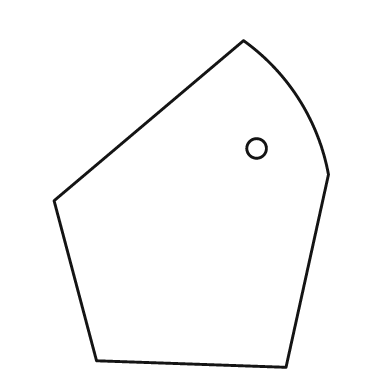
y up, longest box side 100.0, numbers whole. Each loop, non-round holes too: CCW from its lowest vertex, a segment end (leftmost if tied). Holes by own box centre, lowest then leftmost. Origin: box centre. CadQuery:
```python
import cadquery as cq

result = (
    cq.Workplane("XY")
    .moveTo(29.0, -50.0)
    .lineTo(42.0, 9.0)
    .threePointArc((33.0, 32.0), (16.0, 50.0))
    .lineTo(-42.0, 1.0)
    .lineTo(-29.0, -48.0)
    .close()
    .moveTo(20.0, 17.0)
    .circle(3.0)
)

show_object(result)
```